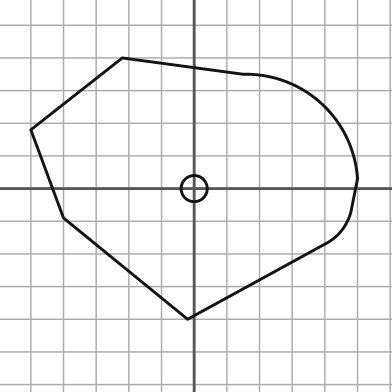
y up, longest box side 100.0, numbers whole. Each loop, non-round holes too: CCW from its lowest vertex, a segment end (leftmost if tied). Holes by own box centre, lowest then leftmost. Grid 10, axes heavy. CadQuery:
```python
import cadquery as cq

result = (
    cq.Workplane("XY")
    .moveTo(-2.0, -40.0)
    .lineTo(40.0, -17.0)
    .threePointArc((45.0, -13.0), (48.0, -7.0))
    .lineTo(50.0, 3.0)
    .threePointArc((39.0, 26.0), (15.0, 35.0))
    .lineTo(-22.0, 40.0)
    .lineTo(-50.0, 18.0)
    .lineTo(-40.0, -9.0)
    .close()
    .moveTo(0.0, 0.0)
    .circle(4.0)
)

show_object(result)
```